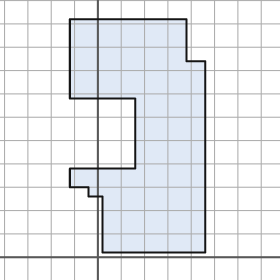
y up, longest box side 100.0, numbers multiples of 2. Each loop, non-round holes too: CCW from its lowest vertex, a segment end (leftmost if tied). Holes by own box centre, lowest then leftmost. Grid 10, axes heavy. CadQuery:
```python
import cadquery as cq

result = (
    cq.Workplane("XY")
    .moveTo(2.0, 2.0)
    .lineTo(46.0, 2.0)
    .lineTo(46.0, 84.0)
    .lineTo(38.0, 84.0)
    .lineTo(38.0, 102.0)
    .lineTo(-12.0, 102.0)
    .lineTo(-12.0, 68.0)
    .lineTo(16.0, 68.0)
    .lineTo(16.0, 38.0)
    .lineTo(-12.0, 38.0)
    .lineTo(-12.0, 30.0)
    .lineTo(-4.0, 30.0)
    .lineTo(-4.0, 26.0)
    .lineTo(2.0, 26.0)
    .close()
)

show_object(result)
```